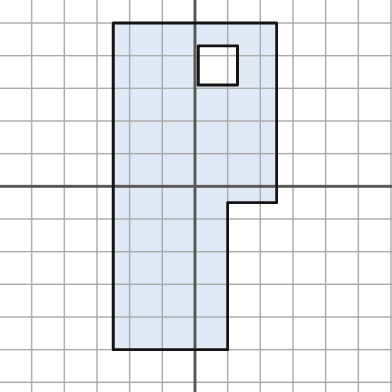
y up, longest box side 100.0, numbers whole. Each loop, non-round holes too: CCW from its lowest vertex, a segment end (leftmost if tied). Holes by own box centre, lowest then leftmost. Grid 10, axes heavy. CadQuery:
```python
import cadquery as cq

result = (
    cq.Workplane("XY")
    .moveTo(-25.0, -50.0)
    .lineTo(10.0, -50.0)
    .lineTo(10.0, -5.0)
    .lineTo(25.0, -5.0)
    .lineTo(25.0, 50.0)
    .lineTo(-25.0, 50.0)
    .close()
    .moveTo(1.0, 31.0)
    .lineTo(13.0, 31.0)
    .lineTo(13.0, 43.0)
    .lineTo(1.0, 43.0)
    .close()
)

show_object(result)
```